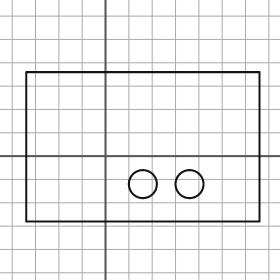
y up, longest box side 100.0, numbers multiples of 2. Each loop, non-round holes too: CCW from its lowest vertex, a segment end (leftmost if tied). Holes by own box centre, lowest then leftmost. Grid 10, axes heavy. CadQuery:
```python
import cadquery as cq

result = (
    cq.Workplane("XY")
    .moveTo(-34.0, -28.0)
    .lineTo(66.0, -28.0)
    .lineTo(66.0, 36.0)
    .lineTo(-34.0, 36.0)
    .close()
    .moveTo(16.0, -12.0)
    .circle(6.0)
    .moveTo(36.0, -12.0)
    .circle(6.0)
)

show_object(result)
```